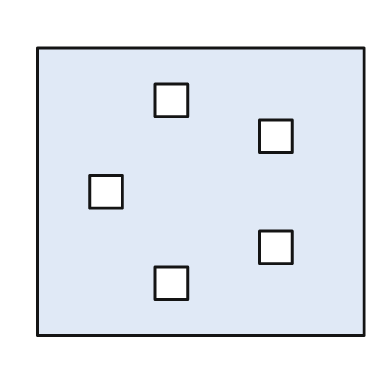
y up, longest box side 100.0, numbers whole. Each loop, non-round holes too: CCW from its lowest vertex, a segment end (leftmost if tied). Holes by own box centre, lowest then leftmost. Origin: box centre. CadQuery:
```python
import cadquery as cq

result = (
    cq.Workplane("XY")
    .moveTo(-50.0, -44.0)
    .lineTo(50.0, -44.0)
    .lineTo(50.0, 44.0)
    .lineTo(-50.0, 44.0)
    .close()
    .moveTo(-14.0, -33.0)
    .lineTo(-4.0, -33.0)
    .lineTo(-4.0, -23.0)
    .lineTo(-14.0, -23.0)
    .close()
    .moveTo(18.0, -22.0)
    .lineTo(28.0, -22.0)
    .lineTo(28.0, -12.0)
    .lineTo(18.0, -12.0)
    .close()
    .moveTo(-34.0, -5.0)
    .lineTo(-24.0, -5.0)
    .lineTo(-24.0, 5.0)
    .lineTo(-34.0, 5.0)
    .close()
    .moveTo(18.0, 12.0)
    .lineTo(28.0, 12.0)
    .lineTo(28.0, 22.0)
    .lineTo(18.0, 22.0)
    .close()
    .moveTo(-14.0, 23.0)
    .lineTo(-4.0, 23.0)
    .lineTo(-4.0, 33.0)
    .lineTo(-14.0, 33.0)
    .close()
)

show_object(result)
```